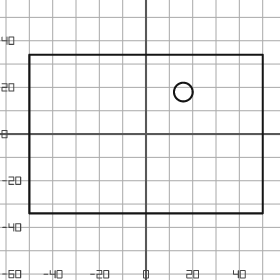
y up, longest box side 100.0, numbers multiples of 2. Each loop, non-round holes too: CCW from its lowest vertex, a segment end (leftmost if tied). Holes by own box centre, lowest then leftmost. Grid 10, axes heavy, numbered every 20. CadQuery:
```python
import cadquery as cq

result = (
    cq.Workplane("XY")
    .moveTo(-50.0, -34.0)
    .lineTo(50.0, -34.0)
    .lineTo(50.0, 34.0)
    .lineTo(-50.0, 34.0)
    .close()
    .moveTo(16.0, 18.0)
    .circle(4.0)
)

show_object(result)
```